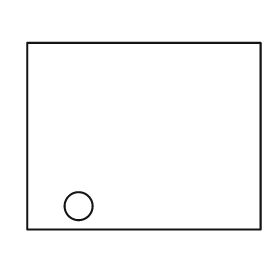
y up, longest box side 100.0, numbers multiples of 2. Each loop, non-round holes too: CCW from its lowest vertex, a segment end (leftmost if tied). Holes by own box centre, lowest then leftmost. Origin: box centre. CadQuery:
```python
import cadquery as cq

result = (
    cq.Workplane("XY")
    .moveTo(-50.0, -40.0)
    .lineTo(50.0, -40.0)
    .lineTo(50.0, 40.0)
    .lineTo(-50.0, 40.0)
    .close()
    .moveTo(-28.0, -30.0)
    .circle(6.0)
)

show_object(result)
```